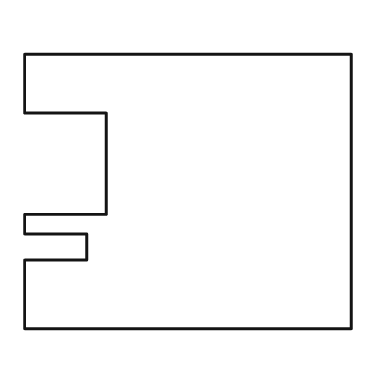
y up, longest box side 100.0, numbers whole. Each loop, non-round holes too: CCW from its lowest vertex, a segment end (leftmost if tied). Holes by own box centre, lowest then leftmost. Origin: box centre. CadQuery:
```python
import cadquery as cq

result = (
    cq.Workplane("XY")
    .moveTo(-50.0, -42.0)
    .lineTo(50.0, -42.0)
    .lineTo(50.0, 42.0)
    .lineTo(-50.0, 42.0)
    .lineTo(-50.0, 24.0)
    .lineTo(-25.0, 24.0)
    .lineTo(-25.0, -7.0)
    .lineTo(-50.0, -7.0)
    .lineTo(-50.0, -13.0)
    .lineTo(-31.0, -13.0)
    .lineTo(-31.0, -21.0)
    .lineTo(-50.0, -21.0)
    .close()
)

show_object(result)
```